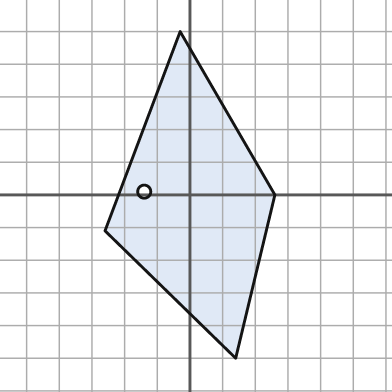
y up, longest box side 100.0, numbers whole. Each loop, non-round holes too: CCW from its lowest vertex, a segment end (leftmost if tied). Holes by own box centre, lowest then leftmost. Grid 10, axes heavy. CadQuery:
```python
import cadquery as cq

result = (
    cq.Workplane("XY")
    .moveTo(14.0, -50.0)
    .lineTo(26.0, 0.0)
    .lineTo(-3.0, 50.0)
    .lineTo(-26.0, -11.0)
    .close()
    .moveTo(-14.0, 1.0)
    .circle(2.0)
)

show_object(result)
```